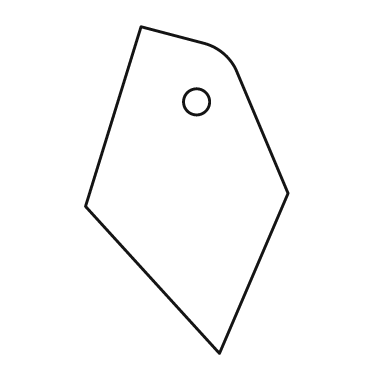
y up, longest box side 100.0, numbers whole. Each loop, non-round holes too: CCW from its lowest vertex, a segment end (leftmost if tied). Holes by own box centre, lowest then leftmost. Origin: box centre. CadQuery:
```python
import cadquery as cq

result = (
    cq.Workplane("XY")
    .moveTo(10.0, -50.0)
    .lineTo(31.0, -1.0)
    .lineTo(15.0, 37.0)
    .threePointArc((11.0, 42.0), (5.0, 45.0))
    .lineTo(-14.0, 50.0)
    .lineTo(-31.0, -5.0)
    .close()
    .moveTo(3.0, 27.0)
    .circle(4.0)
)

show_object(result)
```